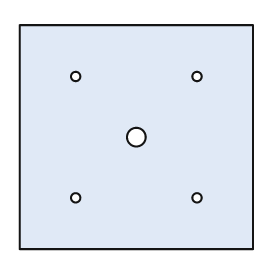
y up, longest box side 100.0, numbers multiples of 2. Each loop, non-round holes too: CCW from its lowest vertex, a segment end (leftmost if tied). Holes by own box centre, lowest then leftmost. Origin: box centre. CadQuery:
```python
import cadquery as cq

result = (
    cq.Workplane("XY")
    .moveTo(-50.0, -48.0)
    .lineTo(50.0, -48.0)
    .lineTo(50.0, 48.0)
    .lineTo(-50.0, 48.0)
    .close()
    .moveTo(-26.0, -26.0)
    .circle(2.0)
    .moveTo(26.0, -26.0)
    .circle(2.0)
    .moveTo(0.0, 0.0)
    .circle(4.0)
    .moveTo(-26.0, 26.0)
    .circle(2.0)
    .moveTo(26.0, 26.0)
    .circle(2.0)
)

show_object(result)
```